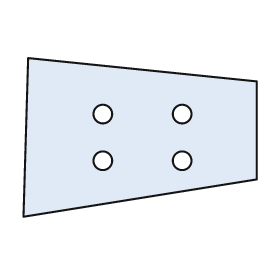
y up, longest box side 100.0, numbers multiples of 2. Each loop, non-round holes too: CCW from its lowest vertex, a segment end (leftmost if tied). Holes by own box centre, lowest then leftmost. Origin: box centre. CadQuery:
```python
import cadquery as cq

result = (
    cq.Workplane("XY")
    .moveTo(-50.0, -34.0)
    .lineTo(50.0, -18.0)
    .lineTo(50.0, 24.0)
    .lineTo(-48.0, 34.0)
    .close()
    .moveTo(-16.0, -10.0)
    .circle(4.0)
    .moveTo(18.0, -10.0)
    .circle(4.0)
    .moveTo(-16.0, 10.0)
    .circle(4.0)
    .moveTo(18.0, 10.0)
    .circle(4.0)
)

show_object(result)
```